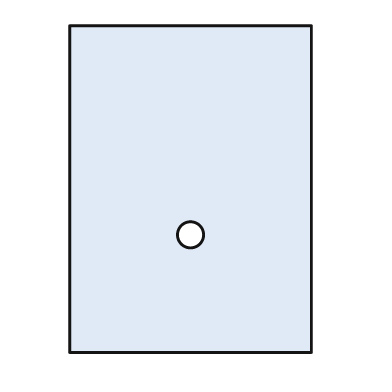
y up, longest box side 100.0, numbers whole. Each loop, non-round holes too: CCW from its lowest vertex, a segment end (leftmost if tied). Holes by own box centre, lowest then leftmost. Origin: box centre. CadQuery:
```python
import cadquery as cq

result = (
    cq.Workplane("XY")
    .moveTo(-37.0, -50.0)
    .lineTo(37.0, -50.0)
    .lineTo(37.0, 50.0)
    .lineTo(-37.0, 50.0)
    .close()
    .moveTo(0.0, -14.0)
    .circle(4.0)
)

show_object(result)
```